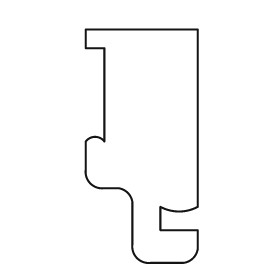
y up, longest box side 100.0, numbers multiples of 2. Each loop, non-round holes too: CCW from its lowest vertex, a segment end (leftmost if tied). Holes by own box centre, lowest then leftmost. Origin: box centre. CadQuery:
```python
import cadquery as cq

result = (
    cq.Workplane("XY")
    .moveTo(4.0, -50.0)
    .lineTo(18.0, -50.0)
    .threePointArc((22.0, -48.0), (24.0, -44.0))
    .lineTo(24.0, -36.0)
    .lineTo(8.0, -36.0)
    .lineTo(8.0, -26.0)
    .threePointArc((16.0, -28.0), (24.0, -26.0))
    .lineTo(24.0, 50.0)
    .lineTo(-24.0, 50.0)
    .lineTo(-24.0, 42.0)
    .lineTo(-16.0, 42.0)
    .lineTo(-16.0, 2.0)
    .threePointArc((-20.0, 4.0), (-24.0, 2.0))
    .lineTo(-24.0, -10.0)
    .threePointArc((-22.0, -16.0), (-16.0, -18.0))
    .lineTo(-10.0, -18.0)
    .threePointArc((-6.0, -20.0), (-4.0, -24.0))
    .lineTo(-4.0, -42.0)
    .threePointArc((-2.0, -48.0), (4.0, -50.0))
    .close()
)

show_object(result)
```